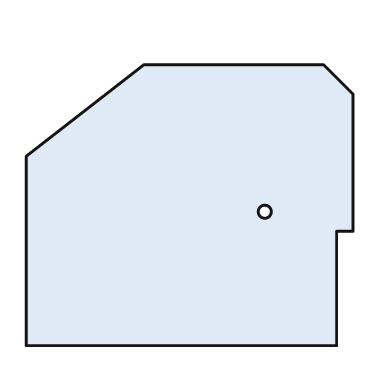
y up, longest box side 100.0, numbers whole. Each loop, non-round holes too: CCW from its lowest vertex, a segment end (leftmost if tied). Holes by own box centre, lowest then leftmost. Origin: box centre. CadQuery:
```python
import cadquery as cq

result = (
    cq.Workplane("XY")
    .moveTo(-50.0, -43.0)
    .lineTo(45.0, -43.0)
    .lineTo(45.0, -8.0)
    .lineTo(50.0, -8.0)
    .lineTo(50.0, 34.0)
    .lineTo(41.0, 43.0)
    .lineTo(-14.0, 43.0)
    .lineTo(-50.0, 15.0)
    .close()
    .moveTo(23.0, -2.0)
    .circle(2.0)
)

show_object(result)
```